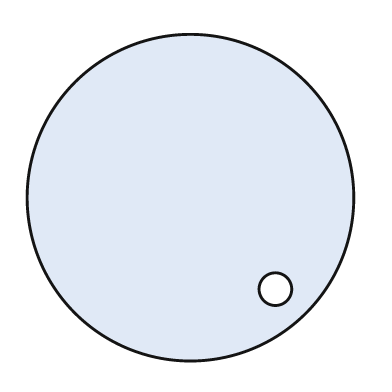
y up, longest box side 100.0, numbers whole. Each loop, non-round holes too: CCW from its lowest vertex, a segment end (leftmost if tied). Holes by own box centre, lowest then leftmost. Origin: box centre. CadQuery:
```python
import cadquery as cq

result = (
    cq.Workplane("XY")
    .moveTo(0.0, 0.0)
    .circle(50.0)
    .moveTo(26.0, -28.0)
    .circle(5.0)
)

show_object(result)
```